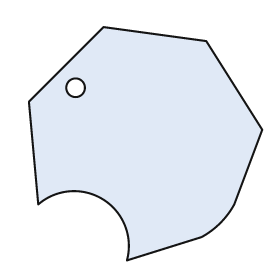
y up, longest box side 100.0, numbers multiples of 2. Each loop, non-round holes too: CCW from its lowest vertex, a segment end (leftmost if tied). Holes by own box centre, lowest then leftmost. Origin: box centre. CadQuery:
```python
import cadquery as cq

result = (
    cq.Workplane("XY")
    .moveTo(-8.0, -50.0)
    .lineTo(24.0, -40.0)
    .threePointArc((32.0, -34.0), (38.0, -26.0))
    .lineTo(50.0, 6.0)
    .lineTo(26.0, 44.0)
    .lineTo(-18.0, 50.0)
    .lineTo(-50.0, 18.0)
    .lineTo(-46.0, -26.0)
    .threePointArc((-18.0, -24.0), (-8.0, -50.0))
    .close()
    .moveTo(-30.0, 24.0)
    .circle(4.0)
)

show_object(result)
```